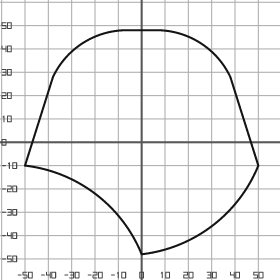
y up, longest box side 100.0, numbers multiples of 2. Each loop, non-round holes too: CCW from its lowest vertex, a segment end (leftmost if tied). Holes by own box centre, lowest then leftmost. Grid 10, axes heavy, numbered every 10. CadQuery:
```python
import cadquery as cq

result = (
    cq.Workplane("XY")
    .moveTo(0.0, -48.0)
    .threePointArc((30.0, -36.0), (50.0, -10.0))
    .lineTo(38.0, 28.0)
    .threePointArc((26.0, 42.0), (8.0, 48.0))
    .lineTo(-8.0, 48.0)
    .threePointArc((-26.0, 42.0), (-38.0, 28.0))
    .lineTo(-50.0, -10.0)
    .threePointArc((-20.0, -22.0), (0.0, -48.0))
    .close()
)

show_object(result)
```